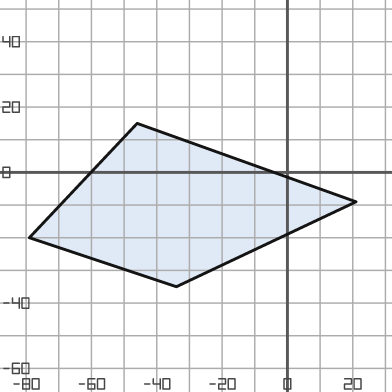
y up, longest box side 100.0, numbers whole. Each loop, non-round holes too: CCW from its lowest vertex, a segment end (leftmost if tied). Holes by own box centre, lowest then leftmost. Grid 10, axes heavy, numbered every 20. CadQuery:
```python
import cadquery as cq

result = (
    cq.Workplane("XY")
    .moveTo(-34.0, -35.0)
    .lineTo(21.0, -9.0)
    .lineTo(-46.0, 15.0)
    .lineTo(-79.0, -20.0)
    .close()
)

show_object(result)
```